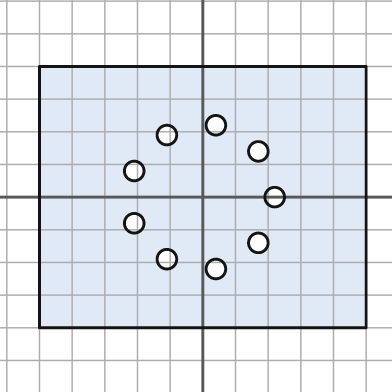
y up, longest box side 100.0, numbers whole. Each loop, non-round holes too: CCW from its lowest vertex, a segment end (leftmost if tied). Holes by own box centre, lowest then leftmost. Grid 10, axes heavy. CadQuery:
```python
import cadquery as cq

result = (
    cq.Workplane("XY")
    .moveTo(-50.0, -40.0)
    .lineTo(50.0, -40.0)
    .lineTo(50.0, 40.0)
    .lineTo(-50.0, 40.0)
    .close()
    .moveTo(4.0, -22.0)
    .circle(3.0)
    .moveTo(-11.0, -19.0)
    .circle(3.0)
    .moveTo(17.0, -14.0)
    .circle(3.0)
    .moveTo(-21.0, -8.0)
    .circle(3.0)
    .moveTo(22.0, 0.0)
    .circle(3.0)
    .moveTo(-21.0, 8.0)
    .circle(3.0)
    .moveTo(17.0, 14.0)
    .circle(3.0)
    .moveTo(-11.0, 19.0)
    .circle(3.0)
    .moveTo(4.0, 22.0)
    .circle(3.0)
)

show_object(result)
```